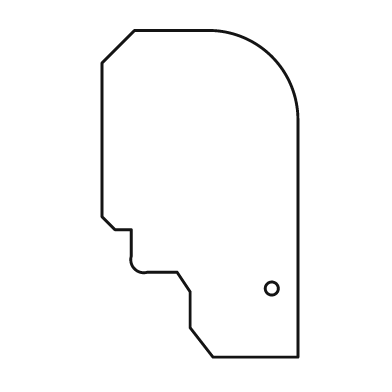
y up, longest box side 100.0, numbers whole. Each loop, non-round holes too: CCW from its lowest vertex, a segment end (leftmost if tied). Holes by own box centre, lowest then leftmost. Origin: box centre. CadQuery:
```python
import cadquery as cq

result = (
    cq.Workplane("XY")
    .moveTo(4.0, -50.0)
    .lineTo(30.0, -50.0)
    .lineTo(30.0, 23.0)
    .threePointArc((22.0, 42.0), (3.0, 50.0))
    .lineTo(-20.0, 50.0)
    .lineTo(-30.0, 40.0)
    .lineTo(-30.0, -7.0)
    .lineTo(-26.0, -11.0)
    .lineTo(-21.0, -11.0)
    .lineTo(-21.0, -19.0)
    .threePointArc((-20.0, -23.0), (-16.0, -24.0))
    .lineTo(-7.0, -24.0)
    .lineTo(-3.0, -30.0)
    .lineTo(-3.0, -41.0)
    .close()
    .moveTo(22.0, -29.0)
    .circle(2.0)
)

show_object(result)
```